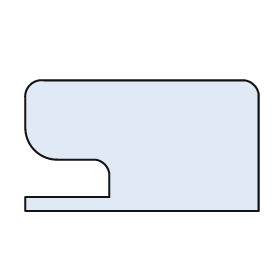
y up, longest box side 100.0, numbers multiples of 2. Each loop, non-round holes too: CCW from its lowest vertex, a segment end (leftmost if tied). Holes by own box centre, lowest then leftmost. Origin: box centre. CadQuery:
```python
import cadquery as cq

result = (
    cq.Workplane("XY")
    .moveTo(-50.0, -28.0)
    .lineTo(50.0, -28.0)
    .lineTo(50.0, 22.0)
    .threePointArc((48.0, 26.0), (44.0, 28.0))
    .lineTo(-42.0, 28.0)
    .threePointArc((-48.0, 26.0), (-50.0, 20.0))
    .lineTo(-50.0, 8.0)
    .threePointArc((-46.0, -2.0), (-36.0, -6.0))
    .lineTo(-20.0, -6.0)
    .threePointArc((-16.0, -8.0), (-14.0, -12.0))
    .lineTo(-14.0, -22.0)
    .lineTo(-50.0, -22.0)
    .close()
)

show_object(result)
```